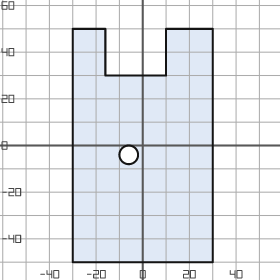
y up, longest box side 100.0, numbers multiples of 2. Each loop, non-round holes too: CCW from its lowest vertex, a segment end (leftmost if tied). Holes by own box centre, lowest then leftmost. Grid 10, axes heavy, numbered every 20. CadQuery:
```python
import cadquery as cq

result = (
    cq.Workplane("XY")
    .moveTo(-30.0, -50.0)
    .lineTo(30.0, -50.0)
    .lineTo(30.0, 50.0)
    .lineTo(10.0, 50.0)
    .lineTo(10.0, 30.0)
    .lineTo(-16.0, 30.0)
    .lineTo(-16.0, 50.0)
    .lineTo(-30.0, 50.0)
    .close()
    .moveTo(-6.0, -4.0)
    .circle(4.0)
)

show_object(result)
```